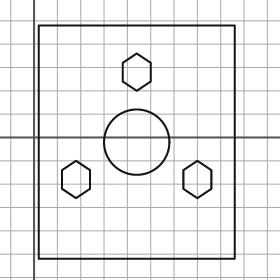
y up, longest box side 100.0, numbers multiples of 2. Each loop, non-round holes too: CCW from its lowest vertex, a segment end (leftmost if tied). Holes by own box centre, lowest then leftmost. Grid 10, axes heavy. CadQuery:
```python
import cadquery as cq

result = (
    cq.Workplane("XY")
    .moveTo(2.0, -52.0)
    .lineTo(86.0, -52.0)
    .lineTo(86.0, 48.0)
    .lineTo(2.0, 48.0)
    .close()
    .moveTo(18.0, -26.0)
    .lineTo(24.0, -22.0)
    .lineTo(24.0, -14.0)
    .lineTo(18.0, -10.0)
    .lineTo(12.0, -14.0)
    .lineTo(12.0, -22.0)
    .close()
    .moveTo(70.0, -26.0)
    .lineTo(76.0, -22.0)
    .lineTo(76.0, -14.0)
    .lineTo(70.0, -10.0)
    .lineTo(64.0, -14.0)
    .lineTo(64.0, -22.0)
    .close()
    .moveTo(44.0, -2.0)
    .circle(14.0)
    .moveTo(44.0, 20.0)
    .lineTo(50.0, 24.0)
    .lineTo(50.0, 32.0)
    .lineTo(44.0, 36.0)
    .lineTo(38.0, 32.0)
    .lineTo(38.0, 24.0)
    .close()
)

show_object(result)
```